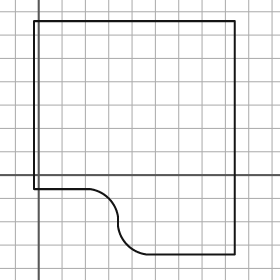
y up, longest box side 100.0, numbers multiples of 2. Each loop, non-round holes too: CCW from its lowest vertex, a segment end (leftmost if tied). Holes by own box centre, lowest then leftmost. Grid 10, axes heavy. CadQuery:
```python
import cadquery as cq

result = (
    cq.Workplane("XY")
    .moveTo(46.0, -34.0)
    .lineTo(84.0, -34.0)
    .lineTo(84.0, 66.0)
    .lineTo(-2.0, 66.0)
    .lineTo(-2.0, -6.0)
    .lineTo(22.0, -6.0)
    .threePointArc((30.0, -10.0), (34.0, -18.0))
    .lineTo(34.0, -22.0)
    .threePointArc((38.0, -30.0), (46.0, -34.0))
    .close()
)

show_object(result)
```